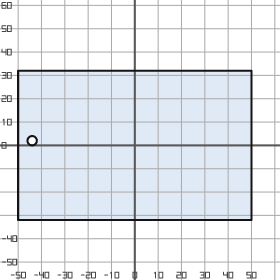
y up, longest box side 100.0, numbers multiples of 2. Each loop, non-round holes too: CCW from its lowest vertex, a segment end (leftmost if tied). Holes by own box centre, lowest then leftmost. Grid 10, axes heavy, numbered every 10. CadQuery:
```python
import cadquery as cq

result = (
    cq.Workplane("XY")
    .moveTo(-50.0, -32.0)
    .lineTo(50.0, -32.0)
    .lineTo(50.0, 32.0)
    .lineTo(-50.0, 32.0)
    .close()
    .moveTo(-44.0, 2.0)
    .circle(2.0)
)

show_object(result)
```